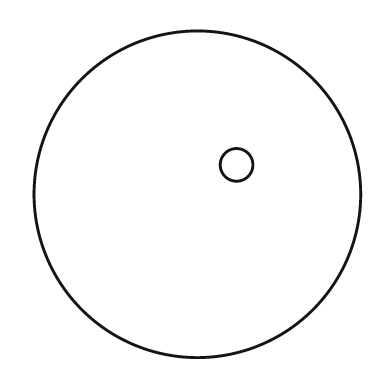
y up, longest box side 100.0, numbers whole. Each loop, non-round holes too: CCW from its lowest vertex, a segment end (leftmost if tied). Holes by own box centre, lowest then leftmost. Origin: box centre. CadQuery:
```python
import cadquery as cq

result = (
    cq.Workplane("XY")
    .moveTo(0.0, 0.0)
    .circle(50.0)
    .moveTo(12.0, 9.0)
    .circle(5.0)
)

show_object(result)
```